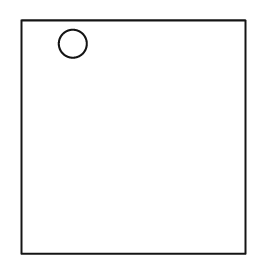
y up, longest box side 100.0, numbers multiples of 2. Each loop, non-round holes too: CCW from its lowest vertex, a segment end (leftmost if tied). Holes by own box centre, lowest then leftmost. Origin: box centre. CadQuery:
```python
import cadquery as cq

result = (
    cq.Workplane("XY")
    .moveTo(-48.0, -50.0)
    .lineTo(48.0, -50.0)
    .lineTo(48.0, 50.0)
    .lineTo(-48.0, 50.0)
    .close()
    .moveTo(-26.0, 40.0)
    .circle(6.0)
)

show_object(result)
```